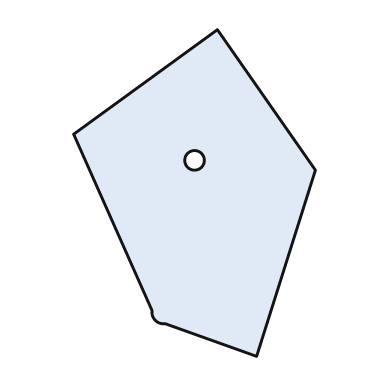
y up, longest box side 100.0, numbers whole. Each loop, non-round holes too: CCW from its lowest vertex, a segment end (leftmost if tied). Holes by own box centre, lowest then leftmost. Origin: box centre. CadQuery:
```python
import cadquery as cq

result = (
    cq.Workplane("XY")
    .moveTo(19.0, -50.0)
    .lineTo(37.0, 7.0)
    .lineTo(7.0, 50.0)
    .lineTo(-37.0, 18.0)
    .lineTo(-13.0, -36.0)
    .threePointArc((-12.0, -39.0), (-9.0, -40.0))
    .close()
    .moveTo(0.0, 10.0)
    .circle(3.0)
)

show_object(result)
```